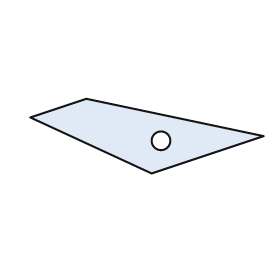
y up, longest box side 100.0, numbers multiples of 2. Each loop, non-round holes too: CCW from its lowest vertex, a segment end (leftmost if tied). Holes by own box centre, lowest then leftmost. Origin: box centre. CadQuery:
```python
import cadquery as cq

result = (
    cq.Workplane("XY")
    .moveTo(2.0, -16.0)
    .lineTo(50.0, 0.0)
    .lineTo(-26.0, 16.0)
    .lineTo(-50.0, 8.0)
    .close()
    .moveTo(6.0, -2.0)
    .circle(4.0)
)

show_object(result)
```